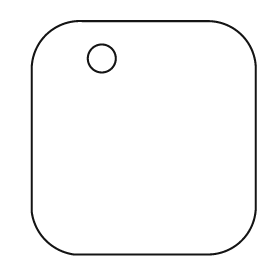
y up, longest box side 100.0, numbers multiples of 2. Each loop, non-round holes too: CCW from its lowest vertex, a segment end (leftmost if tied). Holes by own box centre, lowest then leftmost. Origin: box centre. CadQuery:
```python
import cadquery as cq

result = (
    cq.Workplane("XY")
    .moveTo(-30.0, -50.0)
    .lineTo(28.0, -50.0)
    .threePointArc((42.0, -44.0), (48.0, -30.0))
    .lineTo(48.0, 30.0)
    .threePointArc((42.0, 44.0), (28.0, 50.0))
    .lineTo(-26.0, 50.0)
    .threePointArc((-42.0, 44.0), (-48.0, 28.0))
    .lineTo(-48.0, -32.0)
    .threePointArc((-42.0, -44.0), (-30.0, -50.0))
    .close()
    .moveTo(-18.0, 34.0)
    .circle(6.0)
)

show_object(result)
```